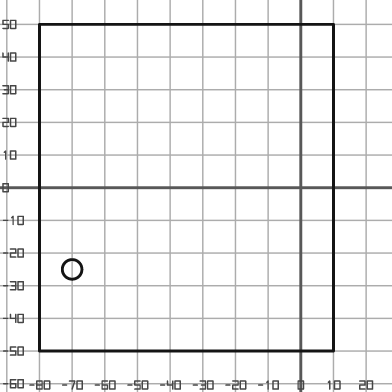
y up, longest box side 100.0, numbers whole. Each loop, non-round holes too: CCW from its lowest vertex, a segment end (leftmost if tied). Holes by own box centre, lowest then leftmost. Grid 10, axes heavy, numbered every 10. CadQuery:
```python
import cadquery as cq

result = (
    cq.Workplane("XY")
    .moveTo(-80.0, -50.0)
    .lineTo(10.0, -50.0)
    .lineTo(10.0, 50.0)
    .lineTo(-80.0, 50.0)
    .close()
    .moveTo(-70.0, -25.0)
    .circle(3.0)
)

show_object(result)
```